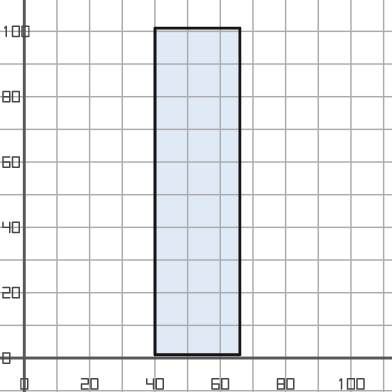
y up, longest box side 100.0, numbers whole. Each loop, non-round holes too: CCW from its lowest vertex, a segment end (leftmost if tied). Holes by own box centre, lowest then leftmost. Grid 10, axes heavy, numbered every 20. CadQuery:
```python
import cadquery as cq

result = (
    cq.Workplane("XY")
    .moveTo(40.0, 1.0)
    .lineTo(66.0, 1.0)
    .lineTo(66.0, 101.0)
    .lineTo(40.0, 101.0)
    .close()
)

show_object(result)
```